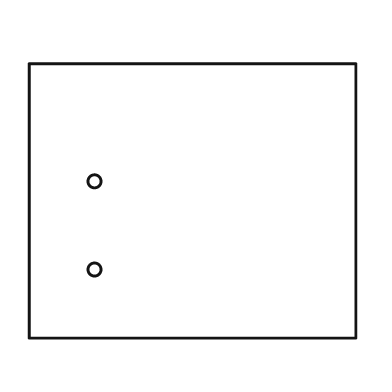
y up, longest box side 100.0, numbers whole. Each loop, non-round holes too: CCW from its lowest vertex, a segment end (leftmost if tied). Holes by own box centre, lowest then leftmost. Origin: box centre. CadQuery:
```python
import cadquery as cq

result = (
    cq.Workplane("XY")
    .moveTo(-50.0, -42.0)
    .lineTo(50.0, -42.0)
    .lineTo(50.0, 42.0)
    .lineTo(-50.0, 42.0)
    .close()
    .moveTo(-30.0, -21.0)
    .circle(2.0)
    .moveTo(-30.0, 6.0)
    .circle(2.0)
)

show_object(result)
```